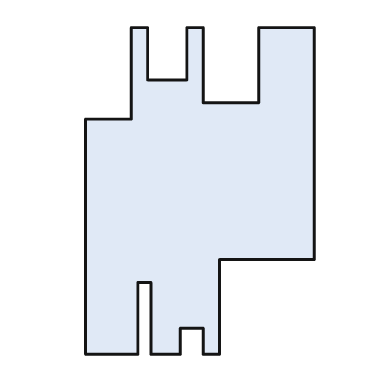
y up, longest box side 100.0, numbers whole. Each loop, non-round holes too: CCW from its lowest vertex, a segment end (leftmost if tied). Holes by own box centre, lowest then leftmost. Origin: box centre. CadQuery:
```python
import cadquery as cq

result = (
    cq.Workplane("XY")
    .moveTo(-35.0, -50.0)
    .lineTo(-19.0, -50.0)
    .lineTo(-19.0, -28.0)
    .lineTo(-15.0, -28.0)
    .lineTo(-15.0, -50.0)
    .lineTo(-6.0, -50.0)
    .lineTo(-6.0, -42.0)
    .lineTo(1.0, -42.0)
    .lineTo(1.0, -50.0)
    .lineTo(6.0, -50.0)
    .lineTo(6.0, -21.0)
    .lineTo(35.0, -21.0)
    .lineTo(35.0, 50.0)
    .lineTo(18.0, 50.0)
    .lineTo(18.0, 27.0)
    .lineTo(1.0, 27.0)
    .lineTo(1.0, 50.0)
    .lineTo(-4.0, 50.0)
    .lineTo(-4.0, 34.0)
    .lineTo(-16.0, 34.0)
    .lineTo(-16.0, 50.0)
    .lineTo(-21.0, 50.0)
    .lineTo(-21.0, 22.0)
    .lineTo(-35.0, 22.0)
    .close()
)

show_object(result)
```